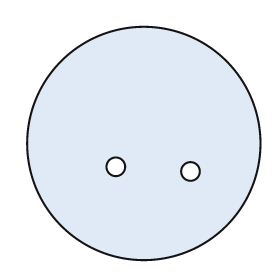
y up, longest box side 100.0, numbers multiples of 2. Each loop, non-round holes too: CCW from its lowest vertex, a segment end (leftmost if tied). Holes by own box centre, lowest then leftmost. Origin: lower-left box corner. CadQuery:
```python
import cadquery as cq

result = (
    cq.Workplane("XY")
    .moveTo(50.0, 50.0)
    .circle(50.0)
    .moveTo(70.0, 38.0)
    .circle(4.0)
    .moveTo(38.0, 40.0)
    .circle(4.0)
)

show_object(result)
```